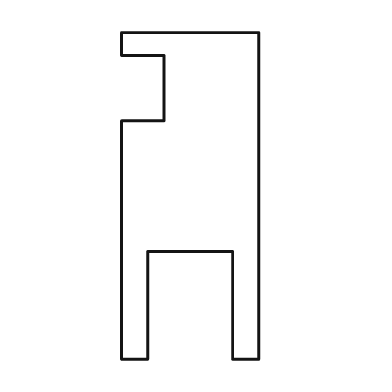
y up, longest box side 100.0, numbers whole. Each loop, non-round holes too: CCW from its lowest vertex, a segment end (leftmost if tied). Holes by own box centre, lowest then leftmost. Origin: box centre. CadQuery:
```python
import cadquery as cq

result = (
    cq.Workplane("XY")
    .moveTo(-21.0, -50.0)
    .lineTo(-13.0, -50.0)
    .lineTo(-13.0, -17.0)
    .lineTo(13.0, -17.0)
    .lineTo(13.0, -50.0)
    .lineTo(21.0, -50.0)
    .lineTo(21.0, 50.0)
    .lineTo(-21.0, 50.0)
    .lineTo(-21.0, 43.0)
    .lineTo(-8.0, 43.0)
    .lineTo(-8.0, 23.0)
    .lineTo(-21.0, 23.0)
    .close()
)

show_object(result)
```